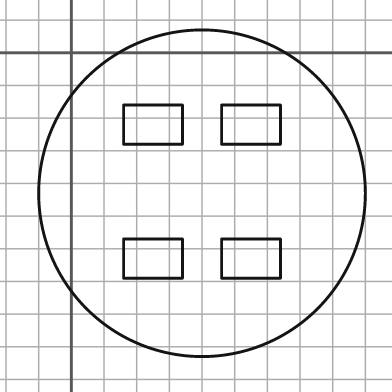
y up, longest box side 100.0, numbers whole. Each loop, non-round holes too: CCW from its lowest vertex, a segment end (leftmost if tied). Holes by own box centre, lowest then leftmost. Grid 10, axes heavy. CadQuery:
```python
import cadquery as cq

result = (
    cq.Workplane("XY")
    .moveTo(40.0, -43.0)
    .circle(50.0)
    .moveTo(16.0, -69.0)
    .lineTo(34.0, -69.0)
    .lineTo(34.0, -57.0)
    .lineTo(16.0, -57.0)
    .close()
    .moveTo(46.0, -69.0)
    .lineTo(64.0, -69.0)
    .lineTo(64.0, -57.0)
    .lineTo(46.0, -57.0)
    .close()
    .moveTo(16.0, -28.0)
    .lineTo(34.0, -28.0)
    .lineTo(34.0, -16.0)
    .lineTo(16.0, -16.0)
    .close()
    .moveTo(46.0, -28.0)
    .lineTo(64.0, -28.0)
    .lineTo(64.0, -16.0)
    .lineTo(46.0, -16.0)
    .close()
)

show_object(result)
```